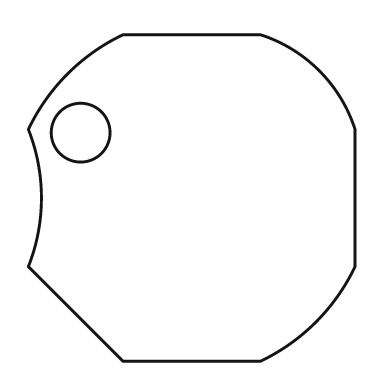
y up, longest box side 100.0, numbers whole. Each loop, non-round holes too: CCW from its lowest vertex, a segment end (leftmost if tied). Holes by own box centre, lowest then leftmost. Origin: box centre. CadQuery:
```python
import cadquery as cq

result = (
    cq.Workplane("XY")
    .moveTo(-21.0, -50.0)
    .lineTo(21.0, -50.0)
    .threePointArc((38.0, -38.0), (50.0, -21.0))
    .lineTo(50.0, 21.0)
    .threePointArc((39.0, 39.0), (21.0, 50.0))
    .lineTo(-21.0, 50.0)
    .threePointArc((-38.0, 38.0), (-50.0, 21.0))
    .threePointArc((-46.0, 0.0), (-50.0, -21.0))
    .close()
    .moveTo(-34.0, 20.0)
    .circle(9.0)
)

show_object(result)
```